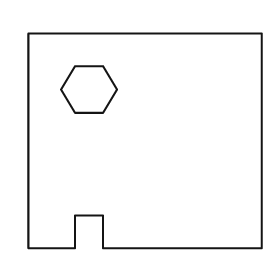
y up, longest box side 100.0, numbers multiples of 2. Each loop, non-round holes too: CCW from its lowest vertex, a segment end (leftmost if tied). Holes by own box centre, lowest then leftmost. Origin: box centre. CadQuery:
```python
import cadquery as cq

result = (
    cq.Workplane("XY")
    .moveTo(-50.0, -46.0)
    .lineTo(-30.0, -46.0)
    .lineTo(-30.0, -32.0)
    .lineTo(-18.0, -32.0)
    .lineTo(-18.0, -46.0)
    .lineTo(50.0, -46.0)
    .lineTo(50.0, 46.0)
    .lineTo(-50.0, 46.0)
    .close()
    .moveTo(-30.0, 12.0)
    .lineTo(-18.0, 12.0)
    .lineTo(-12.0, 22.0)
    .lineTo(-18.0, 32.0)
    .lineTo(-30.0, 32.0)
    .lineTo(-36.0, 22.0)
    .close()
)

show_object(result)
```